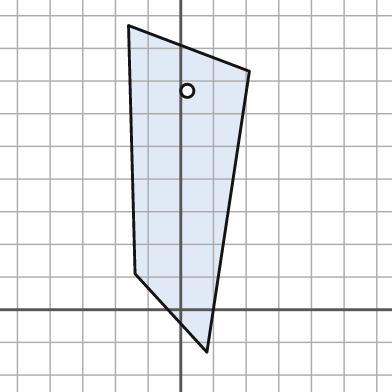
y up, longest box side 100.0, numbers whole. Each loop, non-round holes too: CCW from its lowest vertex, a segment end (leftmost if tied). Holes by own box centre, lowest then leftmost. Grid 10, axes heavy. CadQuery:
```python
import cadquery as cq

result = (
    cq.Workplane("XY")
    .moveTo(8.0, -13.0)
    .lineTo(21.0, 73.0)
    .lineTo(-16.0, 87.0)
    .lineTo(-14.0, 11.0)
    .close()
    .moveTo(2.0, 67.0)
    .circle(2.0)
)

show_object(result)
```